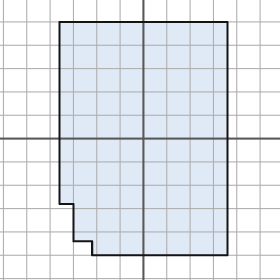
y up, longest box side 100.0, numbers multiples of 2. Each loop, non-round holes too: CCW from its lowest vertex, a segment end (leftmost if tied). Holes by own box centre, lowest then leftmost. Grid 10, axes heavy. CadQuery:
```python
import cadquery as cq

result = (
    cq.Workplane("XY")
    .moveTo(-22.0, -50.0)
    .lineTo(36.0, -50.0)
    .lineTo(36.0, 50.0)
    .lineTo(-36.0, 50.0)
    .lineTo(-36.0, -28.0)
    .lineTo(-30.0, -28.0)
    .lineTo(-30.0, -44.0)
    .lineTo(-22.0, -44.0)
    .close()
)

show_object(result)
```